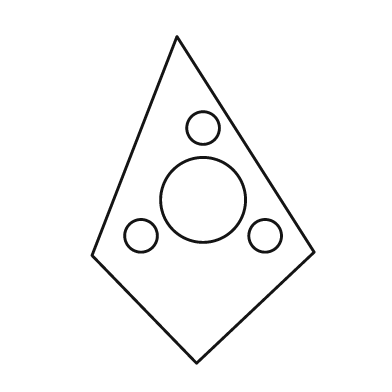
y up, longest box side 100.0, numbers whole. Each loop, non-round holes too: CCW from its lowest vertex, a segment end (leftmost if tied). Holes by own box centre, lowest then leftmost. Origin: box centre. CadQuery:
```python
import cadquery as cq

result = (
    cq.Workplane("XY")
    .moveTo(-2.0, -50.0)
    .lineTo(34.0, -16.0)
    .lineTo(-8.0, 50.0)
    .lineTo(-34.0, -17.0)
    .close()
    .moveTo(-19.0, -11.0)
    .circle(5.0)
    .moveTo(19.0, -11.0)
    .circle(5.0)
    .moveTo(0.0, 0.0)
    .circle(13.0)
    .moveTo(0.0, 22.0)
    .circle(5.0)
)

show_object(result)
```